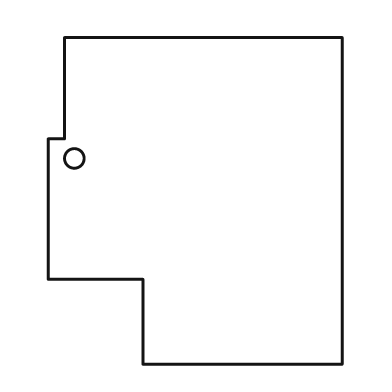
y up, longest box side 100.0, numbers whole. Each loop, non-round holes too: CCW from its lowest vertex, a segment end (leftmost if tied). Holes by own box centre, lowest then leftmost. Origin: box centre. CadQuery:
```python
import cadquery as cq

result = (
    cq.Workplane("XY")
    .moveTo(-16.0, -50.0)
    .lineTo(45.0, -50.0)
    .lineTo(45.0, 50.0)
    .lineTo(-40.0, 50.0)
    .lineTo(-40.0, 19.0)
    .lineTo(-45.0, 19.0)
    .lineTo(-45.0, -24.0)
    .lineTo(-16.0, -24.0)
    .close()
    .moveTo(-37.0, 13.0)
    .circle(3.0)
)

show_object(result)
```